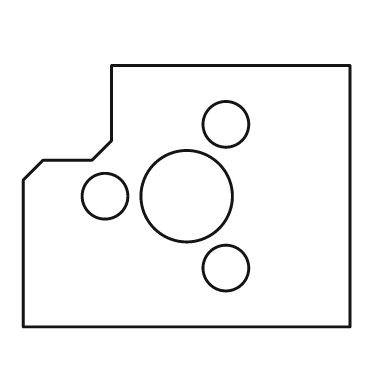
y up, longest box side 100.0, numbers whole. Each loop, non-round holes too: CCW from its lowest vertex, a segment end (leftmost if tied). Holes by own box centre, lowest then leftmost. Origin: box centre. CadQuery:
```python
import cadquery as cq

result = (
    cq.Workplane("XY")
    .moveTo(-50.0, -40.0)
    .lineTo(50.0, -40.0)
    .lineTo(50.0, 40.0)
    .lineTo(-23.0, 40.0)
    .lineTo(-23.0, 17.0)
    .lineTo(-29.0, 11.0)
    .lineTo(-44.0, 11.0)
    .lineTo(-50.0, 5.0)
    .close()
    .moveTo(12.0, -22.0)
    .circle(7.0)
    .moveTo(-25.0, 0.0)
    .circle(7.0)
    .moveTo(0.0, 0.0)
    .circle(14.0)
    .moveTo(12.0, 22.0)
    .circle(7.0)
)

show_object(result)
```